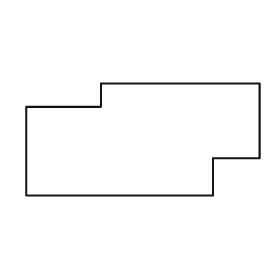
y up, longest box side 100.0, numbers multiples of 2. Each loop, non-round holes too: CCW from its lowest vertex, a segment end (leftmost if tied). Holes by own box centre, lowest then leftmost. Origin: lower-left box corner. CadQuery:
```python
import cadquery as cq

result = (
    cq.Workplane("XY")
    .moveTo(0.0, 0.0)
    .lineTo(80.0, 0.0)
    .lineTo(80.0, 16.0)
    .lineTo(100.0, 16.0)
    .lineTo(100.0, 48.0)
    .lineTo(32.0, 48.0)
    .lineTo(32.0, 38.0)
    .lineTo(0.0, 38.0)
    .close()
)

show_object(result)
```